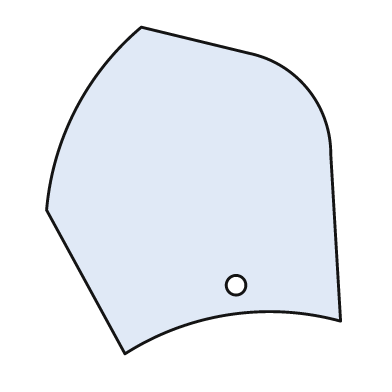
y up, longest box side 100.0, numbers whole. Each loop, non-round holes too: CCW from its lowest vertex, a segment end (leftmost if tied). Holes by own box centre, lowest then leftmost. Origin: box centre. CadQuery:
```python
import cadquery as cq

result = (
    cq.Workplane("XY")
    .moveTo(-21.0, -50.0)
    .threePointArc((11.0, -38.0), (45.0, -40.0))
    .lineTo(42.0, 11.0)
    .threePointArc((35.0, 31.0), (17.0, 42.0))
    .lineTo(-16.0, 50.0)
    .threePointArc((-36.0, 25.0), (-45.0, -6.0))
    .close()
    .moveTo(13.0, -29.0)
    .circle(3.0)
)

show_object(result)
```